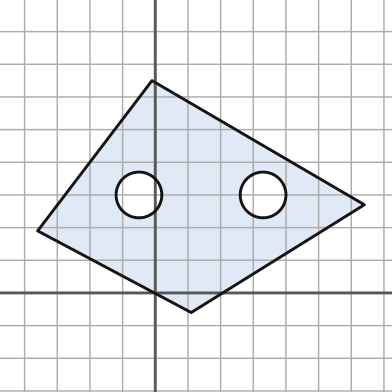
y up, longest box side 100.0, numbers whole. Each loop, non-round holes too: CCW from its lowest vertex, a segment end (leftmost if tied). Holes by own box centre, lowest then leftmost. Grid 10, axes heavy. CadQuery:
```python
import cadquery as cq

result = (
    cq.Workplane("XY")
    .moveTo(11.0, -6.0)
    .lineTo(64.0, 27.0)
    .lineTo(-1.0, 65.0)
    .lineTo(-36.0, 19.0)
    .close()
    .moveTo(-5.0, 30.0)
    .circle(7.0)
    .moveTo(33.0, 30.0)
    .circle(7.0)
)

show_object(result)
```